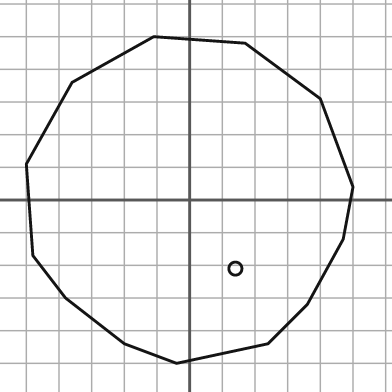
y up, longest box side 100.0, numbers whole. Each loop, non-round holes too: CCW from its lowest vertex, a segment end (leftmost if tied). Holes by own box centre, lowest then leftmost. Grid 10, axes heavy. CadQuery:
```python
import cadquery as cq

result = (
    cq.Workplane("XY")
    .moveTo(-4.0, -50.0)
    .lineTo(24.0, -44.0)
    .lineTo(36.0, -32.0)
    .lineTo(47.0, -12.0)
    .lineTo(50.0, 4.0)
    .lineTo(40.0, 31.0)
    .lineTo(17.0, 48.0)
    .lineTo(-11.0, 50.0)
    .lineTo(-36.0, 36.0)
    .lineTo(-50.0, 11.0)
    .lineTo(-48.0, -17.0)
    .lineTo(-38.0, -30.0)
    .lineTo(-20.0, -44.0)
    .close()
    .moveTo(14.0, -21.0)
    .circle(2.0)
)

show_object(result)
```